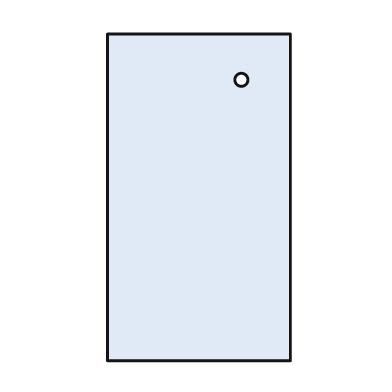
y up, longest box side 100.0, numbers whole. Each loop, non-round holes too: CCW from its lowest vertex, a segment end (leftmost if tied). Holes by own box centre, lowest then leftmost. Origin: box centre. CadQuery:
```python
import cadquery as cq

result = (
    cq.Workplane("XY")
    .moveTo(-28.0, -50.0)
    .lineTo(28.0, -50.0)
    .lineTo(28.0, 50.0)
    .lineTo(-28.0, 50.0)
    .close()
    .moveTo(13.0, 36.0)
    .circle(2.0)
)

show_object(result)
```